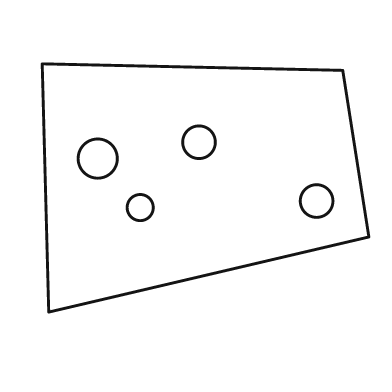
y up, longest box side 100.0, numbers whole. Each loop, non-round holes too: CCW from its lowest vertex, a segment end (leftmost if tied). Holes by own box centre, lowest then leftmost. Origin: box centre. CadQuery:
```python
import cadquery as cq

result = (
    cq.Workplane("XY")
    .moveTo(-48.0, -38.0)
    .lineTo(50.0, -15.0)
    .lineTo(42.0, 36.0)
    .lineTo(-50.0, 38.0)
    .close()
    .moveTo(-20.0, -6.0)
    .circle(4.0)
    .moveTo(34.0, -4.0)
    .circle(5.0)
    .moveTo(-33.0, 9.0)
    .circle(6.0)
    .moveTo(-2.0, 14.0)
    .circle(5.0)
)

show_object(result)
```